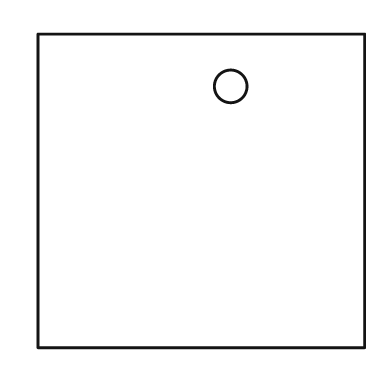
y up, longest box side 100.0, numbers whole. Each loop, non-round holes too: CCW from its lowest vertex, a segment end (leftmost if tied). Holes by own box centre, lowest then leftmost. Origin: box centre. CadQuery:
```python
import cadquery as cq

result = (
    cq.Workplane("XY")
    .moveTo(-50.0, -48.0)
    .lineTo(50.0, -48.0)
    .lineTo(50.0, 48.0)
    .lineTo(-50.0, 48.0)
    .close()
    .moveTo(9.0, 32.0)
    .circle(5.0)
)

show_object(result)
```